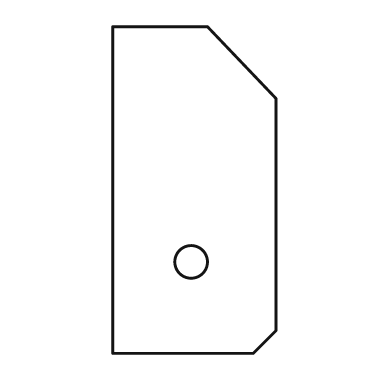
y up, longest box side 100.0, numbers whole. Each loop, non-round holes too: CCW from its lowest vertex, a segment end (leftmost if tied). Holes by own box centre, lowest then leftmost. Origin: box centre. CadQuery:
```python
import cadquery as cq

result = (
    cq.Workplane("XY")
    .moveTo(-25.0, -50.0)
    .lineTo(18.0, -50.0)
    .lineTo(25.0, -43.0)
    .lineTo(25.0, 28.0)
    .lineTo(4.0, 50.0)
    .lineTo(-25.0, 50.0)
    .close()
    .moveTo(-1.0, -22.0)
    .circle(5.0)
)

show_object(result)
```